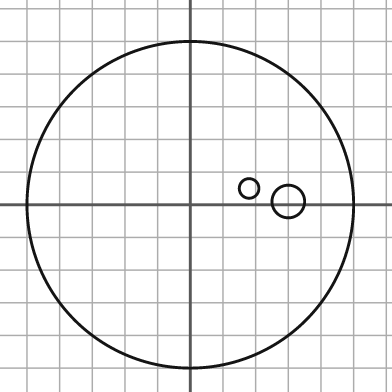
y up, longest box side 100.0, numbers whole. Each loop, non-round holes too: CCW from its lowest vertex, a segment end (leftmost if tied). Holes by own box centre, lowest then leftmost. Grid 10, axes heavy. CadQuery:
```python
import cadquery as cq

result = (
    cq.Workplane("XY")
    .moveTo(0.0, 0.0)
    .circle(50.0)
    .moveTo(30.0, 1.0)
    .circle(5.0)
    .moveTo(18.0, 5.0)
    .circle(3.0)
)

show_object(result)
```